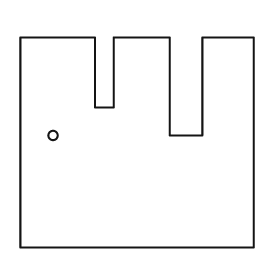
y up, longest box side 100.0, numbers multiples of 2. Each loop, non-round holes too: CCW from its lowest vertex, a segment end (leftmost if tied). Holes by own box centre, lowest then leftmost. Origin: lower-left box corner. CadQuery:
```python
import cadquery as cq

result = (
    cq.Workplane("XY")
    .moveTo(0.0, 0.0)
    .lineTo(100.0, 0.0)
    .lineTo(100.0, 90.0)
    .lineTo(78.0, 90.0)
    .lineTo(78.0, 48.0)
    .lineTo(64.0, 48.0)
    .lineTo(64.0, 90.0)
    .lineTo(40.0, 90.0)
    .lineTo(40.0, 60.0)
    .lineTo(32.0, 60.0)
    .lineTo(32.0, 90.0)
    .lineTo(0.0, 90.0)
    .close()
    .moveTo(14.0, 48.0)
    .circle(2.0)
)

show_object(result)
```